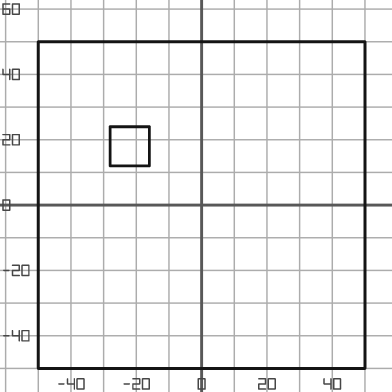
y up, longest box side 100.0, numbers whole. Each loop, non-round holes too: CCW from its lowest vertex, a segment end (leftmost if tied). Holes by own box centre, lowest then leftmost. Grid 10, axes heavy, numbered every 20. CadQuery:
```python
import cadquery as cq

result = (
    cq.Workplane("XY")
    .moveTo(-50.0, -50.0)
    .lineTo(50.0, -50.0)
    .lineTo(50.0, 50.0)
    .lineTo(-50.0, 50.0)
    .close()
    .moveTo(-28.0, 12.0)
    .lineTo(-16.0, 12.0)
    .lineTo(-16.0, 24.0)
    .lineTo(-28.0, 24.0)
    .close()
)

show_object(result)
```